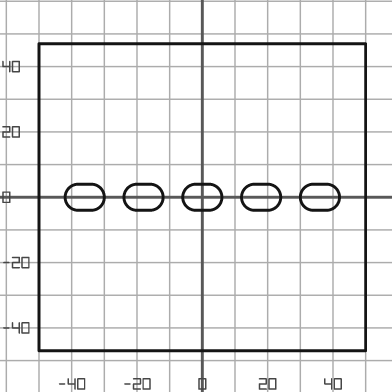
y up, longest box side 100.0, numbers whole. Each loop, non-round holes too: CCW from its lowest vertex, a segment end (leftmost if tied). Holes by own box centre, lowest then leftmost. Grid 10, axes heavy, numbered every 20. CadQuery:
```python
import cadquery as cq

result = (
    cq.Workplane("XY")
    .moveTo(-50.0, -47.0)
    .lineTo(50.0, -47.0)
    .lineTo(50.0, 47.0)
    .lineTo(-50.0, 47.0)
    .close()
    .moveTo(-38.0, -4.0)
    .lineTo(-34.0, -4.0)
    .threePointArc((-30.0, 0.0), (-34.0, 4.0))
    .lineTo(-38.0, 4.0)
    .threePointArc((-42.0, 0.0), (-38.0, -4.0))
    .close()
    .moveTo(-20.0, -4.0)
    .lineTo(-16.0, -4.0)
    .threePointArc((-12.0, 0.0), (-16.0, 4.0))
    .lineTo(-20.0, 4.0)
    .threePointArc((-24.0, 0.0), (-20.0, -4.0))
    .close()
    .moveTo(-2.0, -4.0)
    .lineTo(2.0, -4.0)
    .threePointArc((6.0, 0.0), (2.0, 4.0))
    .lineTo(-2.0, 4.0)
    .threePointArc((-6.0, 0.0), (-2.0, -4.0))
    .close()
    .moveTo(16.0, -4.0)
    .lineTo(20.0, -4.0)
    .threePointArc((24.0, 0.0), (20.0, 4.0))
    .lineTo(16.0, 4.0)
    .threePointArc((12.0, 0.0), (16.0, -4.0))
    .close()
    .moveTo(34.0, -4.0)
    .lineTo(38.0, -4.0)
    .threePointArc((42.0, 0.0), (38.0, 4.0))
    .lineTo(34.0, 4.0)
    .threePointArc((30.0, 0.0), (34.0, -4.0))
    .close()
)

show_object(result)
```